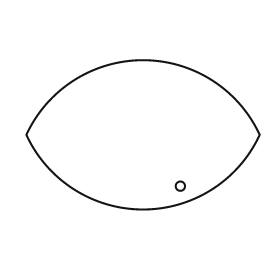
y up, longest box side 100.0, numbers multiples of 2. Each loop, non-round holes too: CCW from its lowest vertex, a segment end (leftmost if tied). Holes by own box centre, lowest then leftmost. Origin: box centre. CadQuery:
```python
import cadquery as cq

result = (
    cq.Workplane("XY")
    .moveTo(-50.0, 0.0)
    .threePointArc((0.0, -32.0), (50.0, 0.0))
    .threePointArc((0.0, 32.0), (-50.0, 0.0))
    .close()
    .moveTo(16.0, -22.0)
    .circle(2.0)
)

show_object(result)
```